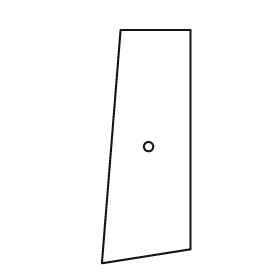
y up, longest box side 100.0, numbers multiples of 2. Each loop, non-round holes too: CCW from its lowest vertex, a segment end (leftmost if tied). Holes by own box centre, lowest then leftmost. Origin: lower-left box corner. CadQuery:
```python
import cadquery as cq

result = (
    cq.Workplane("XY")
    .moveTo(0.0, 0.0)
    .lineTo(38.0, 6.0)
    .lineTo(38.0, 100.0)
    .lineTo(8.0, 100.0)
    .close()
    .moveTo(20.0, 50.0)
    .circle(2.0)
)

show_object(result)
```